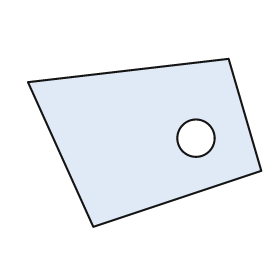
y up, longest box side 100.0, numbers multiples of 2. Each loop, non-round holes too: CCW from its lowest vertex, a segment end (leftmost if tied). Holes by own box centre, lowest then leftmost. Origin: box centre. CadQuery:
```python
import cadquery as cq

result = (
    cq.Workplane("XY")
    .moveTo(-22.0, -36.0)
    .lineTo(50.0, -12.0)
    .lineTo(36.0, 36.0)
    .lineTo(-50.0, 26.0)
    .close()
    .moveTo(22.0, 2.0)
    .circle(8.0)
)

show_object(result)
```